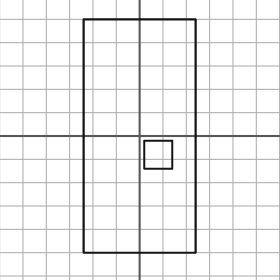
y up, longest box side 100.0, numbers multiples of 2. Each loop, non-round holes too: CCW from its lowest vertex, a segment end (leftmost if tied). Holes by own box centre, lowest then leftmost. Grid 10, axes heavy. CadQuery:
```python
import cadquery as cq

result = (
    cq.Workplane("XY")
    .moveTo(-24.0, -50.0)
    .lineTo(24.0, -50.0)
    .lineTo(24.0, 50.0)
    .lineTo(-24.0, 50.0)
    .close()
    .moveTo(2.0, -14.0)
    .lineTo(14.0, -14.0)
    .lineTo(14.0, -2.0)
    .lineTo(2.0, -2.0)
    .close()
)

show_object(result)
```